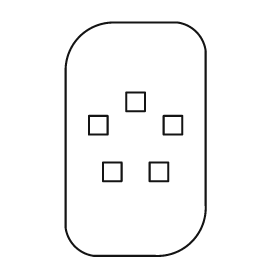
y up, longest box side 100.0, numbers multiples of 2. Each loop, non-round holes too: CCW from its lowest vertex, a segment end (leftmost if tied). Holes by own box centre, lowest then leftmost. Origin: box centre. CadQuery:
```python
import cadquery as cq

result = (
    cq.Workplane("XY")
    .moveTo(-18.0, -50.0)
    .lineTo(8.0, -50.0)
    .threePointArc((24.0, -44.0), (30.0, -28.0))
    .lineTo(30.0, 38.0)
    .threePointArc((26.0, 46.0), (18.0, 50.0))
    .lineTo(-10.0, 50.0)
    .threePointArc((-24.0, 44.0), (-30.0, 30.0))
    .lineTo(-30.0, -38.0)
    .threePointArc((-26.0, -46.0), (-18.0, -50.0))
    .close()
    .moveTo(-14.0, -18.0)
    .lineTo(-6.0, -18.0)
    .lineTo(-6.0, -10.0)
    .lineTo(-14.0, -10.0)
    .close()
    .moveTo(6.0, -18.0)
    .lineTo(14.0, -18.0)
    .lineTo(14.0, -10.0)
    .lineTo(6.0, -10.0)
    .close()
    .moveTo(-20.0, 2.0)
    .lineTo(-12.0, 2.0)
    .lineTo(-12.0, 10.0)
    .lineTo(-20.0, 10.0)
    .close()
    .moveTo(12.0, 2.0)
    .lineTo(20.0, 2.0)
    .lineTo(20.0, 10.0)
    .lineTo(12.0, 10.0)
    .close()
    .moveTo(-4.0, 12.0)
    .lineTo(4.0, 12.0)
    .lineTo(4.0, 20.0)
    .lineTo(-4.0, 20.0)
    .close()
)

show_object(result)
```